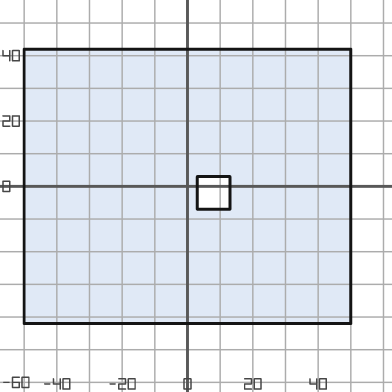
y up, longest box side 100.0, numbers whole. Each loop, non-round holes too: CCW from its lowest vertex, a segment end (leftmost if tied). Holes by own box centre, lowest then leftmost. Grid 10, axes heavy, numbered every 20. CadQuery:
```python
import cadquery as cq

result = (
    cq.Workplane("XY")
    .moveTo(-50.0, -42.0)
    .lineTo(50.0, -42.0)
    .lineTo(50.0, 42.0)
    .lineTo(-50.0, 42.0)
    .close()
    .moveTo(3.0, -7.0)
    .lineTo(13.0, -7.0)
    .lineTo(13.0, 3.0)
    .lineTo(3.0, 3.0)
    .close()
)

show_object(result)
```